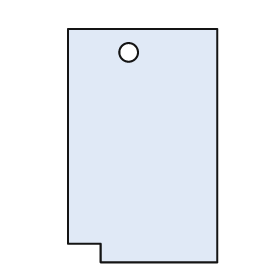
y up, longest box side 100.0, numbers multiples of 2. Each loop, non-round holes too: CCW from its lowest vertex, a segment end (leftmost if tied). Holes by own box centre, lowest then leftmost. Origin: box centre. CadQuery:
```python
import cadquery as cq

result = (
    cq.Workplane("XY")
    .moveTo(-18.0, -50.0)
    .lineTo(32.0, -50.0)
    .lineTo(32.0, 50.0)
    .lineTo(-32.0, 50.0)
    .lineTo(-32.0, -42.0)
    .lineTo(-18.0, -42.0)
    .close()
    .moveTo(-6.0, 40.0)
    .circle(4.0)
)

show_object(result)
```